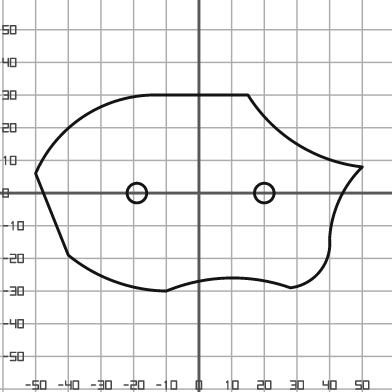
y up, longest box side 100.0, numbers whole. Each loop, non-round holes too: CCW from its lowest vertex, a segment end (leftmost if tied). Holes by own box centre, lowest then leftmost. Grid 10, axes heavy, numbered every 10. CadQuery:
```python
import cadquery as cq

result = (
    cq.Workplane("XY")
    .moveTo(-10.0, -30.0)
    .threePointArc((9.0, -26.0), (28.0, -29.0))
    .threePointArc((37.0, -24.0), (40.0, -14.0))
    .threePointArc((43.0, -2.0), (50.0, 8.0))
    .threePointArc((30.0, 15.0), (15.0, 30.0))
    .lineTo(-15.0, 30.0)
    .threePointArc((-36.0, 23.0), (-50.0, 6.0))
    .lineTo(-40.0, -19.0)
    .threePointArc((-26.0, -27.0), (-10.0, -30.0))
    .close()
    .moveTo(-19.0, 0.0)
    .circle(3.0)
    .moveTo(20.0, 0.0)
    .circle(3.0)
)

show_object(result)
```